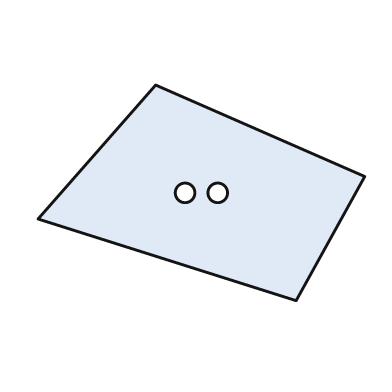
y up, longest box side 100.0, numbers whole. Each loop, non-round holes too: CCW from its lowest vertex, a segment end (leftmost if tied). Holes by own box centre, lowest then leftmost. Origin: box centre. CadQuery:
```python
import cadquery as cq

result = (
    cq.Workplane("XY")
    .moveTo(29.0, -33.0)
    .lineTo(50.0, 5.0)
    .lineTo(-14.0, 33.0)
    .lineTo(-50.0, -8.0)
    .close()
    .moveTo(-5.0, 0.0)
    .circle(3.0)
    .moveTo(5.0, 0.0)
    .circle(3.0)
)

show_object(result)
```